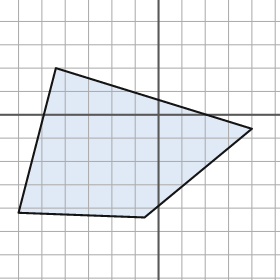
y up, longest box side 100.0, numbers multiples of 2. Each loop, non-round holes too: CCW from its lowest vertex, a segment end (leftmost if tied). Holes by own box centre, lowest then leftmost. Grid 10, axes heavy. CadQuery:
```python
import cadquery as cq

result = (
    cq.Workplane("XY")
    .moveTo(-6.0, -44.0)
    .lineTo(40.0, -6.0)
    .lineTo(-44.0, 20.0)
    .lineTo(-60.0, -42.0)
    .close()
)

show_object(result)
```